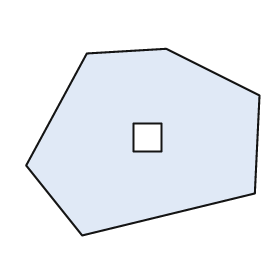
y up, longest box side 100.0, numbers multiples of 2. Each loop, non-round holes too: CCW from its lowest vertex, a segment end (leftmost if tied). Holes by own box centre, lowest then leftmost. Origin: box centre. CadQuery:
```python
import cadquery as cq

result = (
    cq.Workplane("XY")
    .moveTo(-26.0, -40.0)
    .lineTo(48.0, -22.0)
    .lineTo(50.0, 20.0)
    .lineTo(10.0, 40.0)
    .lineTo(-24.0, 38.0)
    .lineTo(-50.0, -10.0)
    .close()
    .moveTo(-4.0, -4.0)
    .lineTo(8.0, -4.0)
    .lineTo(8.0, 8.0)
    .lineTo(-4.0, 8.0)
    .close()
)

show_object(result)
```